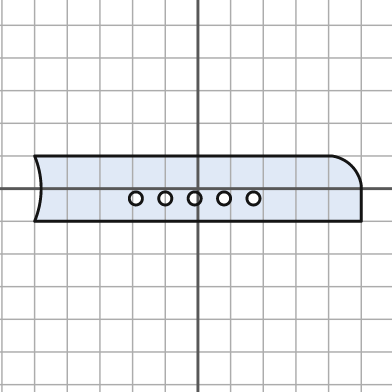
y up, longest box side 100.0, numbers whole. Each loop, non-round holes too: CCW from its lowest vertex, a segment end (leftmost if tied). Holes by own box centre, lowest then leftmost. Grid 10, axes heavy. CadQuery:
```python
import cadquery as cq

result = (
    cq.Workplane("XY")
    .moveTo(-50.0, -10.0)
    .lineTo(50.0, -10.0)
    .lineTo(50.0, 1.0)
    .threePointArc((47.0, 7.0), (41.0, 10.0))
    .lineTo(-50.0, 10.0)
    .threePointArc((-48.0, 0.0), (-50.0, -10.0))
    .close()
    .moveTo(-19.0, -3.0)
    .circle(2.0)
    .moveTo(-10.0, -3.0)
    .circle(2.0)
    .moveTo(-1.0, -3.0)
    .circle(2.0)
    .moveTo(8.0, -3.0)
    .circle(2.0)
    .moveTo(17.0, -3.0)
    .circle(2.0)
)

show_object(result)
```